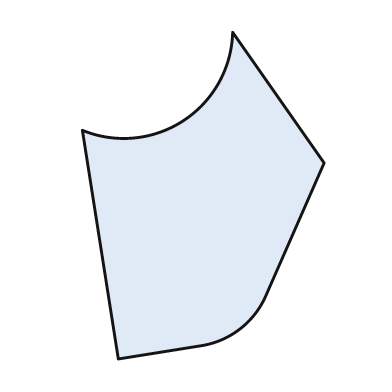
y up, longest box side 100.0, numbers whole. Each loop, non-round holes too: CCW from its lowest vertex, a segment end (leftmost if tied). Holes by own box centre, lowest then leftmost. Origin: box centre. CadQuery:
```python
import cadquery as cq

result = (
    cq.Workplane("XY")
    .moveTo(-26.0, -50.0)
    .lineTo(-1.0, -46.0)
    .threePointArc((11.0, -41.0), (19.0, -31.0))
    .lineTo(37.0, 10.0)
    .lineTo(9.0, 50.0)
    .threePointArc((-6.0, 23.0), (-37.0, 20.0))
    .close()
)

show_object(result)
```